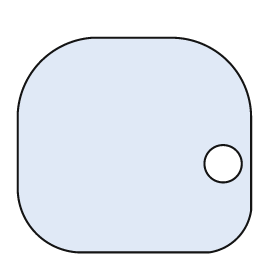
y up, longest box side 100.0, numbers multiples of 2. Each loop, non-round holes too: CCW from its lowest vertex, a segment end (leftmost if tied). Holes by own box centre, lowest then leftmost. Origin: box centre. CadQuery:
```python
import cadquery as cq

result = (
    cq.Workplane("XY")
    .moveTo(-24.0, -46.0)
    .lineTo(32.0, -46.0)
    .threePointArc((44.0, -40.0), (50.0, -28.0))
    .lineTo(50.0, 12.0)
    .threePointArc((40.0, 36.0), (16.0, 46.0))
    .lineTo(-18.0, 46.0)
    .threePointArc((-40.0, 36.0), (-50.0, 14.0))
    .lineTo(-50.0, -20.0)
    .threePointArc((-42.0, -38.0), (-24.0, -46.0))
    .close()
    .moveTo(38.0, -8.0)
    .circle(8.0)
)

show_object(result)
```